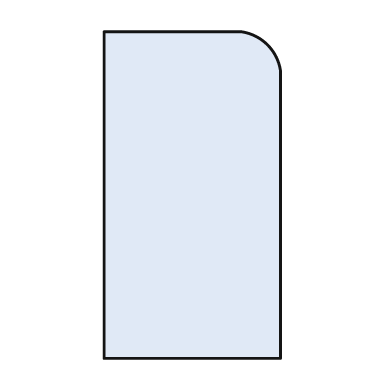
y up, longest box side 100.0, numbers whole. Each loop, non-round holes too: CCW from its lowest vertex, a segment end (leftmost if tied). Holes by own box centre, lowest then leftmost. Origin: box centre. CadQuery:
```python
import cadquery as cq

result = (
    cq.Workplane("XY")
    .moveTo(-27.0, -50.0)
    .lineTo(27.0, -50.0)
    .lineTo(27.0, 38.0)
    .threePointArc((23.0, 46.0), (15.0, 50.0))
    .lineTo(-27.0, 50.0)
    .close()
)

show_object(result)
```